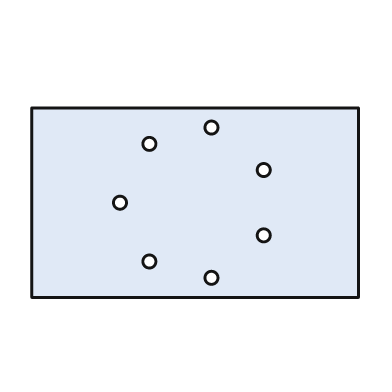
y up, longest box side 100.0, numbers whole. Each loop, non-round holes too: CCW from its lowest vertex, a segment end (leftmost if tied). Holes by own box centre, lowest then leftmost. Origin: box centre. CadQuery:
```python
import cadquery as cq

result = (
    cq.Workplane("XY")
    .moveTo(-50.0, -29.0)
    .lineTo(50.0, -29.0)
    .lineTo(50.0, 29.0)
    .lineTo(-50.0, 29.0)
    .close()
    .moveTo(5.0, -23.0)
    .circle(2.0)
    .moveTo(-14.0, -18.0)
    .circle(2.0)
    .moveTo(21.0, -10.0)
    .circle(2.0)
    .moveTo(-23.0, 0.0)
    .circle(2.0)
    .moveTo(21.0, 10.0)
    .circle(2.0)
    .moveTo(-14.0, 18.0)
    .circle(2.0)
    .moveTo(5.0, 23.0)
    .circle(2.0)
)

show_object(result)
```